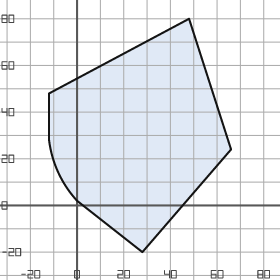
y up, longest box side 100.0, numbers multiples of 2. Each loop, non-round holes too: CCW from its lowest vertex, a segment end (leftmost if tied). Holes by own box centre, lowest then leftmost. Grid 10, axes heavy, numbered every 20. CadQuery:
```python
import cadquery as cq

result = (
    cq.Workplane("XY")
    .moveTo(28.0, -20.0)
    .lineTo(66.0, 24.0)
    .lineTo(48.0, 80.0)
    .lineTo(-12.0, 48.0)
    .lineTo(-12.0, 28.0)
    .threePointArc((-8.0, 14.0), (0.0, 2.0))
    .close()
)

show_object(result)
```